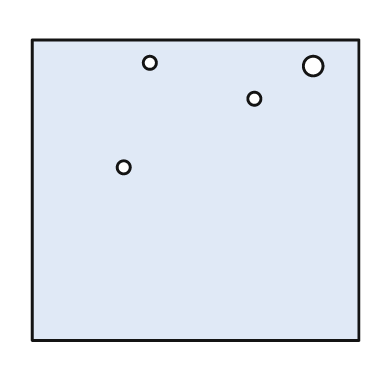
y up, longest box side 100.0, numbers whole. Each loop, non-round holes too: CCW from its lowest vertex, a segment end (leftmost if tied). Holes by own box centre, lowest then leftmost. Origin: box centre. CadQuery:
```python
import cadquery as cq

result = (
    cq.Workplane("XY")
    .moveTo(-50.0, -46.0)
    .lineTo(50.0, -46.0)
    .lineTo(50.0, 46.0)
    .lineTo(-50.0, 46.0)
    .close()
    .moveTo(-22.0, 7.0)
    .circle(2.0)
    .moveTo(18.0, 28.0)
    .circle(2.0)
    .moveTo(36.0, 38.0)
    .circle(3.0)
    .moveTo(-14.0, 39.0)
    .circle(2.0)
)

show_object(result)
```